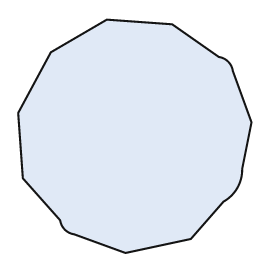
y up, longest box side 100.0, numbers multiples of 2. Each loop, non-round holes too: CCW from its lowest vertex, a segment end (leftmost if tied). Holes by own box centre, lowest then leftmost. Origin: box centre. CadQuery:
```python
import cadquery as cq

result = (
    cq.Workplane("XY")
    .moveTo(-4.0, -50.0)
    .lineTo(24.0, -44.0)
    .lineTo(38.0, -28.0)
    .threePointArc((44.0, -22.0), (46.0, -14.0))
    .lineTo(50.0, 6.0)
    .lineTo(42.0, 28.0)
    .threePointArc((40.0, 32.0), (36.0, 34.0))
    .lineTo(16.0, 48.0)
    .lineTo(-12.0, 50.0)
    .lineTo(-36.0, 36.0)
    .lineTo(-50.0, 10.0)
    .lineTo(-48.0, -18.0)
    .lineTo(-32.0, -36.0)
    .threePointArc((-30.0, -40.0), (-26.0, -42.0))
    .close()
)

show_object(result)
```